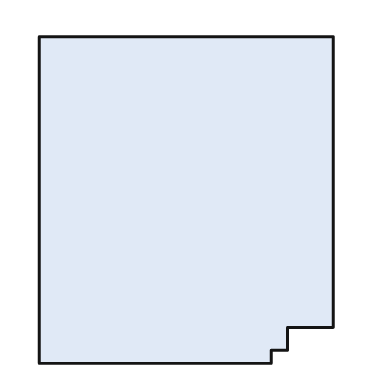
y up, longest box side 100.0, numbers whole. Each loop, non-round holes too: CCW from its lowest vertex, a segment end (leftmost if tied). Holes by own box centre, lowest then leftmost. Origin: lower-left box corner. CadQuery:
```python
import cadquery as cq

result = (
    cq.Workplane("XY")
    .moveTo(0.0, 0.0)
    .lineTo(71.0, 0.0)
    .lineTo(71.0, 4.0)
    .lineTo(76.0, 4.0)
    .lineTo(76.0, 11.0)
    .lineTo(90.0, 11.0)
    .lineTo(90.0, 100.0)
    .lineTo(0.0, 100.0)
    .close()
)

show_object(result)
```